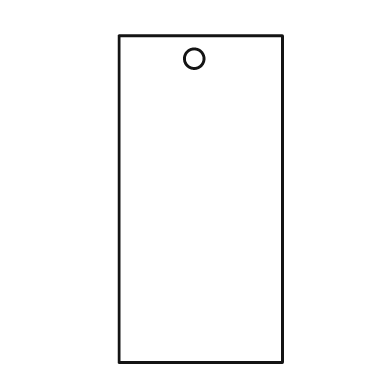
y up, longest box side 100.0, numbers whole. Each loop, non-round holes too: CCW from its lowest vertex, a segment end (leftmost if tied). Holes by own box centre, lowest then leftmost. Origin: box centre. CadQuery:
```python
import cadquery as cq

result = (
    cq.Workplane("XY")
    .moveTo(-25.0, -50.0)
    .lineTo(25.0, -50.0)
    .lineTo(25.0, 50.0)
    .lineTo(-25.0, 50.0)
    .close()
    .moveTo(-2.0, 43.0)
    .circle(3.0)
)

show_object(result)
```